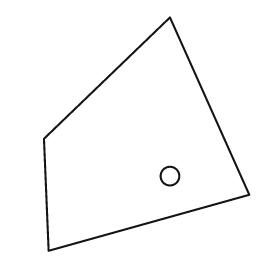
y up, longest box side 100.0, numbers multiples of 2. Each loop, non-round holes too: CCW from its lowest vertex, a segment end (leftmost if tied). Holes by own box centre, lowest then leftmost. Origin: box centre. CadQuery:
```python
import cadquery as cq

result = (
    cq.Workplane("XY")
    .moveTo(-42.0, -50.0)
    .lineTo(44.0, -26.0)
    .lineTo(10.0, 50.0)
    .lineTo(-44.0, -2.0)
    .close()
    .moveTo(10.0, -18.0)
    .circle(4.0)
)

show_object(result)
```